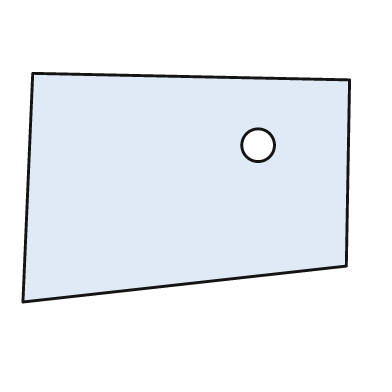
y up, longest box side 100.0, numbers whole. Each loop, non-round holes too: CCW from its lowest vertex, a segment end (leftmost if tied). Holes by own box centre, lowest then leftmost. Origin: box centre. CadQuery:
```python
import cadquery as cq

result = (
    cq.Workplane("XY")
    .moveTo(-50.0, -35.0)
    .lineTo(49.0, -24.0)
    .lineTo(50.0, 33.0)
    .lineTo(-47.0, 35.0)
    .close()
    .moveTo(22.0, 13.0)
    .circle(5.0)
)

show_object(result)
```